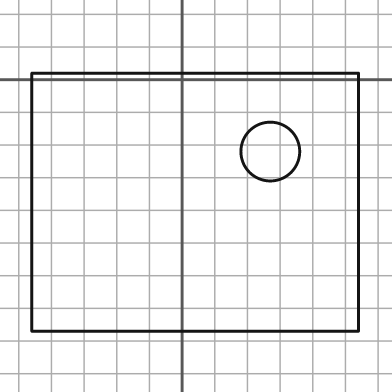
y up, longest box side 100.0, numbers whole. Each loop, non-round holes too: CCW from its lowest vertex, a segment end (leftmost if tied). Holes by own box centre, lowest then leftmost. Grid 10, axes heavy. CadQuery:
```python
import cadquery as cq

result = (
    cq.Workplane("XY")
    .moveTo(-46.0, -77.0)
    .lineTo(54.0, -77.0)
    .lineTo(54.0, 2.0)
    .lineTo(-46.0, 2.0)
    .close()
    .moveTo(27.0, -22.0)
    .circle(9.0)
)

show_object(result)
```